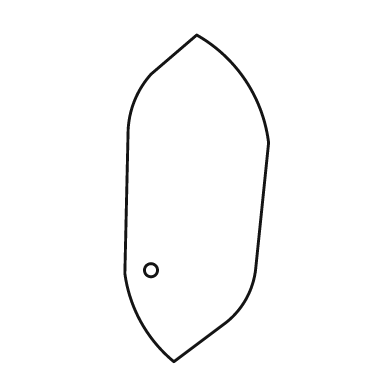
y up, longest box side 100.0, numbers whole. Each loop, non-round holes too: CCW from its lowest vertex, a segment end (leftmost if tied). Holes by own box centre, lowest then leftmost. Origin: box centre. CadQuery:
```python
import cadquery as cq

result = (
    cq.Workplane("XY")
    .moveTo(-7.0, -50.0)
    .lineTo(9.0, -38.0)
    .threePointArc((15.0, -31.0), (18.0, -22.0))
    .lineTo(22.0, 17.0)
    .threePointArc((15.0, 36.0), (0.0, 50.0))
    .lineTo(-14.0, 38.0)
    .threePointArc((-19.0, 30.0), (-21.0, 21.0))
    .lineTo(-22.0, -23.0)
    .threePointArc((-17.0, -38.0), (-7.0, -50.0))
    .close()
    .moveTo(-14.0, -22.0)
    .circle(2.0)
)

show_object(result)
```